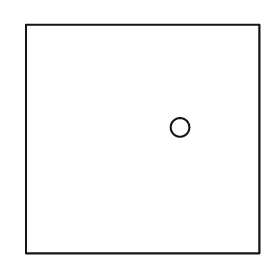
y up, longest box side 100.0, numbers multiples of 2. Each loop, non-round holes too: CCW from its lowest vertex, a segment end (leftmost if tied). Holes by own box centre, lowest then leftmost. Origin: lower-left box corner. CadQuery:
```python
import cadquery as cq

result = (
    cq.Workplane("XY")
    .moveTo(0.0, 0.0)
    .lineTo(100.0, 0.0)
    .lineTo(100.0, 98.0)
    .lineTo(0.0, 98.0)
    .close()
    .moveTo(66.0, 54.0)
    .circle(4.0)
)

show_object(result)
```